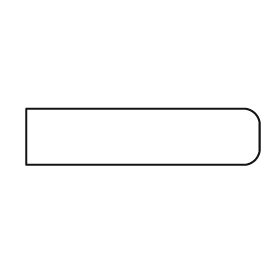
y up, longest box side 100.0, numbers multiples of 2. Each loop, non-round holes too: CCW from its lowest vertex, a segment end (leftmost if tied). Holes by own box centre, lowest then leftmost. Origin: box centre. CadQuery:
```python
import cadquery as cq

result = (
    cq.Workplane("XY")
    .moveTo(-50.0, -12.0)
    .lineTo(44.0, -12.0)
    .threePointArc((48.0, -10.0), (50.0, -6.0))
    .lineTo(50.0, 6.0)
    .threePointArc((48.0, 10.0), (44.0, 12.0))
    .lineTo(-50.0, 12.0)
    .close()
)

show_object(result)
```